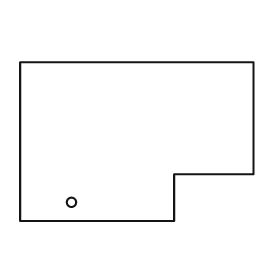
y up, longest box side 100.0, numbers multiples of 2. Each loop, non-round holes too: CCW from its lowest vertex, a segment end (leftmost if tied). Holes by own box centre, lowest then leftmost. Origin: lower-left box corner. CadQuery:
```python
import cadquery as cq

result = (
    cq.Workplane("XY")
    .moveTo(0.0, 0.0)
    .lineTo(66.0, 0.0)
    .lineTo(66.0, 20.0)
    .lineTo(100.0, 20.0)
    .lineTo(100.0, 68.0)
    .lineTo(0.0, 68.0)
    .close()
    .moveTo(22.0, 8.0)
    .circle(2.0)
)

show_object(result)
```